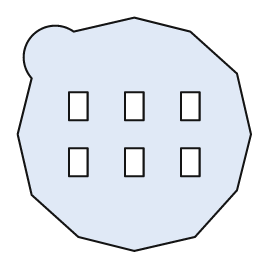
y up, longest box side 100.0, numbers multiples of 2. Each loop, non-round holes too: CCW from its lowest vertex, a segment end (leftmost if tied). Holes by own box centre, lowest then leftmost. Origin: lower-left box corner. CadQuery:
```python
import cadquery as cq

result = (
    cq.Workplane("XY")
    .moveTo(50.0, 0.0)
    .lineTo(76.0, 6.0)
    .lineTo(94.0, 26.0)
    .lineTo(100.0, 50.0)
    .lineTo(94.0, 76.0)
    .lineTo(74.0, 94.0)
    .lineTo(50.0, 100.0)
    .lineTo(24.0, 94.0)
    .threePointArc((6.0, 92.0), (6.0, 74.0))
    .lineTo(0.0, 50.0)
    .lineTo(6.0, 24.0)
    .lineTo(26.0, 6.0)
    .close()
    .moveTo(22.0, 32.0)
    .lineTo(30.0, 32.0)
    .lineTo(30.0, 44.0)
    .lineTo(22.0, 44.0)
    .close()
    .moveTo(46.0, 32.0)
    .lineTo(54.0, 32.0)
    .lineTo(54.0, 44.0)
    .lineTo(46.0, 44.0)
    .close()
    .moveTo(70.0, 32.0)
    .lineTo(78.0, 32.0)
    .lineTo(78.0, 44.0)
    .lineTo(70.0, 44.0)
    .close()
    .moveTo(22.0, 56.0)
    .lineTo(30.0, 56.0)
    .lineTo(30.0, 68.0)
    .lineTo(22.0, 68.0)
    .close()
    .moveTo(46.0, 56.0)
    .lineTo(54.0, 56.0)
    .lineTo(54.0, 68.0)
    .lineTo(46.0, 68.0)
    .close()
    .moveTo(70.0, 56.0)
    .lineTo(78.0, 56.0)
    .lineTo(78.0, 68.0)
    .lineTo(70.0, 68.0)
    .close()
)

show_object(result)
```